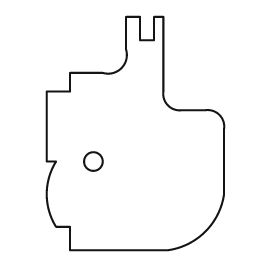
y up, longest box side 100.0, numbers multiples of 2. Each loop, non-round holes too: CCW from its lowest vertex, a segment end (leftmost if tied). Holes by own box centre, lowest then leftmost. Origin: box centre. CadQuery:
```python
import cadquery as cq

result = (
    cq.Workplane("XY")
    .moveTo(-28.0, -50.0)
    .lineTo(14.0, -50.0)
    .threePointArc((30.0, -42.0), (38.0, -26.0))
    .lineTo(38.0, 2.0)
    .threePointArc((36.0, 8.0), (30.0, 10.0))
    .lineTo(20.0, 10.0)
    .threePointArc((14.0, 12.0), (12.0, 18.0))
    .lineTo(12.0, 50.0)
    .lineTo(8.0, 50.0)
    .lineTo(8.0, 40.0)
    .lineTo(2.0, 40.0)
    .lineTo(2.0, 50.0)
    .lineTo(-4.0, 50.0)
    .lineTo(-4.0, 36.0)
    .threePointArc((-6.0, 28.0), (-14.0, 26.0))
    .lineTo(-28.0, 26.0)
    .lineTo(-28.0, 18.0)
    .lineTo(-38.0, 18.0)
    .lineTo(-38.0, -12.0)
    .lineTo(-34.0, -12.0)
    .threePointArc((-38.0, -26.0), (-34.0, -40.0))
    .lineTo(-28.0, -40.0)
    .close()
    .moveTo(-18.0, -12.0)
    .circle(4.0)
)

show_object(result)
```